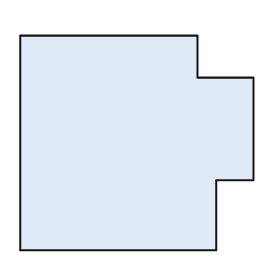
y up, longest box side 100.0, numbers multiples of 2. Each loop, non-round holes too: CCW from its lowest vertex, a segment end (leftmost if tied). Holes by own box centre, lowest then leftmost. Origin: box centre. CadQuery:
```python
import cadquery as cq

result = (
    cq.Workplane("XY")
    .moveTo(-50.0, -46.0)
    .lineTo(34.0, -46.0)
    .lineTo(34.0, -16.0)
    .lineTo(50.0, -16.0)
    .lineTo(50.0, 28.0)
    .lineTo(26.0, 28.0)
    .lineTo(26.0, 46.0)
    .lineTo(-50.0, 46.0)
    .close()
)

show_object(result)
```